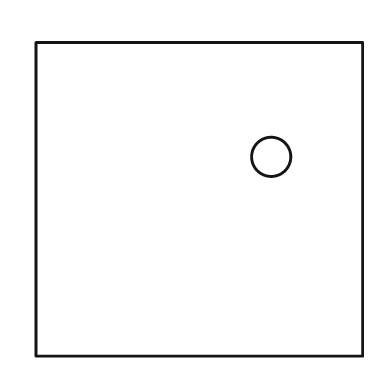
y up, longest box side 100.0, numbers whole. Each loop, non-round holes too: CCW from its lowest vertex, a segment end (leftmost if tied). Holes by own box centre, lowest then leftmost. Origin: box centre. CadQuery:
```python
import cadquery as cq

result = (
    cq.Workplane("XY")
    .moveTo(-50.0, -48.0)
    .lineTo(50.0, -48.0)
    .lineTo(50.0, 48.0)
    .lineTo(-50.0, 48.0)
    .close()
    .moveTo(22.0, 13.0)
    .circle(6.0)
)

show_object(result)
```